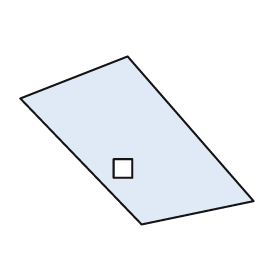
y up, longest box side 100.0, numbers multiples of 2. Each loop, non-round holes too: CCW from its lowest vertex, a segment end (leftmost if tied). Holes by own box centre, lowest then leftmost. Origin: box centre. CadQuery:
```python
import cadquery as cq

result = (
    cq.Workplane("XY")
    .moveTo(2.0, -36.0)
    .lineTo(50.0, -26.0)
    .lineTo(-4.0, 36.0)
    .lineTo(-50.0, 18.0)
    .close()
    .moveTo(-10.0, -16.0)
    .lineTo(-2.0, -16.0)
    .lineTo(-2.0, -8.0)
    .lineTo(-10.0, -8.0)
    .close()
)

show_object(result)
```